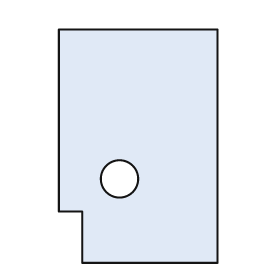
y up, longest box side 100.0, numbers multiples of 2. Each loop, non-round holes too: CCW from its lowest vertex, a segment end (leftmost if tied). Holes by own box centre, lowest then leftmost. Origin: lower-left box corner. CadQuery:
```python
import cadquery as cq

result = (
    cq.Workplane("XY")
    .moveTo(10.0, 0.0)
    .lineTo(68.0, 0.0)
    .lineTo(68.0, 100.0)
    .lineTo(0.0, 100.0)
    .lineTo(0.0, 22.0)
    .lineTo(10.0, 22.0)
    .close()
    .moveTo(26.0, 36.0)
    .circle(8.0)
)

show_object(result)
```